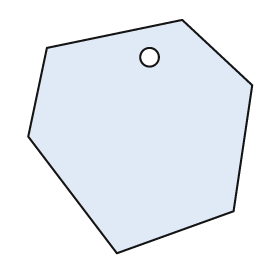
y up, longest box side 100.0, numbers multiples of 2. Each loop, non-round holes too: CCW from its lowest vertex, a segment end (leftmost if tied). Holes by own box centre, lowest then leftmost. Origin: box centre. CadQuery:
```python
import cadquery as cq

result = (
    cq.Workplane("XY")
    .moveTo(-10.0, -50.0)
    .lineTo(40.0, -32.0)
    .lineTo(48.0, 22.0)
    .lineTo(18.0, 50.0)
    .lineTo(-40.0, 38.0)
    .lineTo(-48.0, 0.0)
    .close()
    .moveTo(4.0, 34.0)
    .circle(4.0)
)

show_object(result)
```